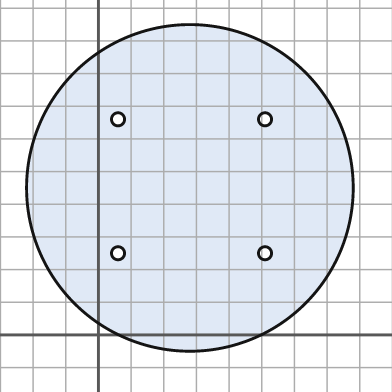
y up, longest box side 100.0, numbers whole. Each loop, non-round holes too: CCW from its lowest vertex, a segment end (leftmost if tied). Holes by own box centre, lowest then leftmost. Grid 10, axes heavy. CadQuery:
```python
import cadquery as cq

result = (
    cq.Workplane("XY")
    .moveTo(28.0, 45.0)
    .circle(50.0)
    .moveTo(6.0, 25.0)
    .circle(2.0)
    .moveTo(51.0, 25.0)
    .circle(2.0)
    .moveTo(6.0, 66.0)
    .circle(2.0)
    .moveTo(51.0, 66.0)
    .circle(2.0)
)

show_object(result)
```